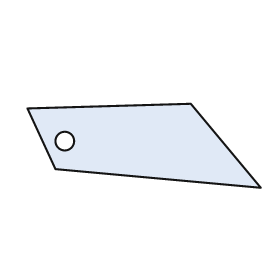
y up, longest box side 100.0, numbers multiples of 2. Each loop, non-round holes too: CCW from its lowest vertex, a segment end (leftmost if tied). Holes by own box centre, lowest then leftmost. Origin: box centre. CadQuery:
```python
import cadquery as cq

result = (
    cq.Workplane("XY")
    .moveTo(50.0, -18.0)
    .lineTo(20.0, 18.0)
    .lineTo(-50.0, 16.0)
    .lineTo(-38.0, -10.0)
    .close()
    .moveTo(-34.0, 2.0)
    .circle(4.0)
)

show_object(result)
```